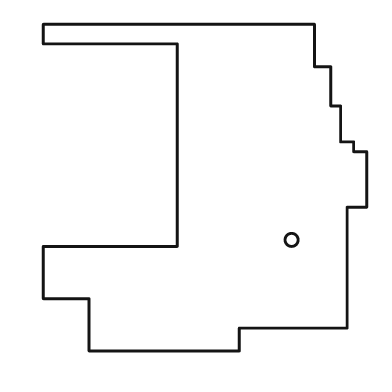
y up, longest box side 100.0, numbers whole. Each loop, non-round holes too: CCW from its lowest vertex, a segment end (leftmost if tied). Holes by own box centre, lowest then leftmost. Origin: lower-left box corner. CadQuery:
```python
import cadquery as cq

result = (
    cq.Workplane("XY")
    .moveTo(14.0, 0.0)
    .lineTo(60.0, 0.0)
    .lineTo(60.0, 7.0)
    .lineTo(93.0, 7.0)
    .lineTo(93.0, 44.0)
    .lineTo(99.0, 44.0)
    .lineTo(99.0, 61.0)
    .lineTo(95.0, 61.0)
    .lineTo(95.0, 64.0)
    .lineTo(91.0, 64.0)
    .lineTo(91.0, 75.0)
    .lineTo(88.0, 75.0)
    .lineTo(88.0, 87.0)
    .lineTo(83.0, 87.0)
    .lineTo(83.0, 100.0)
    .lineTo(0.0, 100.0)
    .lineTo(0.0, 94.0)
    .lineTo(41.0, 94.0)
    .lineTo(41.0, 32.0)
    .lineTo(0.0, 32.0)
    .lineTo(0.0, 16.0)
    .lineTo(14.0, 16.0)
    .close()
    .moveTo(76.0, 34.0)
    .circle(2.0)
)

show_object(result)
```